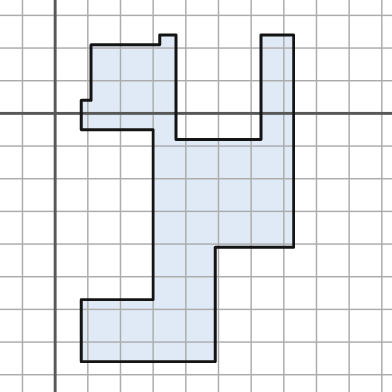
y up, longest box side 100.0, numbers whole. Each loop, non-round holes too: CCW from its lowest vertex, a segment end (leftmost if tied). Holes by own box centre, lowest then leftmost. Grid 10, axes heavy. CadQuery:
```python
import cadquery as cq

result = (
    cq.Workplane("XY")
    .moveTo(8.0, -76.0)
    .lineTo(49.0, -76.0)
    .lineTo(49.0, -41.0)
    .lineTo(73.0, -41.0)
    .lineTo(73.0, 24.0)
    .lineTo(63.0, 24.0)
    .lineTo(63.0, -8.0)
    .lineTo(37.0, -8.0)
    .lineTo(37.0, 24.0)
    .lineTo(32.0, 24.0)
    .lineTo(32.0, 21.0)
    .lineTo(11.0, 21.0)
    .lineTo(11.0, 4.0)
    .lineTo(8.0, 4.0)
    .lineTo(8.0, -5.0)
    .lineTo(30.0, -5.0)
    .lineTo(30.0, -57.0)
    .lineTo(8.0, -57.0)
    .close()
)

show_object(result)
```